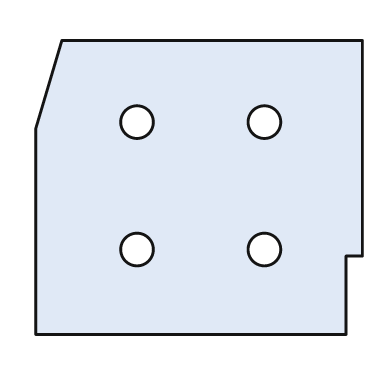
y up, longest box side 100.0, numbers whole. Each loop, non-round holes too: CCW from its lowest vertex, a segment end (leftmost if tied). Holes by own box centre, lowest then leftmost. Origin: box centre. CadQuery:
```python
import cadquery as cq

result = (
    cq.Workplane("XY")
    .moveTo(-50.0, -45.0)
    .lineTo(45.0, -45.0)
    .lineTo(45.0, -21.0)
    .lineTo(50.0, -21.0)
    .lineTo(50.0, 45.0)
    .lineTo(-42.0, 45.0)
    .lineTo(-50.0, 18.0)
    .close()
    .moveTo(-19.0, -19.0)
    .circle(5.0)
    .moveTo(20.0, -19.0)
    .circle(5.0)
    .moveTo(-19.0, 20.0)
    .circle(5.0)
    .moveTo(20.0, 20.0)
    .circle(5.0)
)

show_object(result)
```